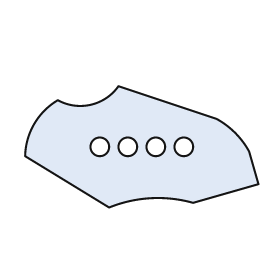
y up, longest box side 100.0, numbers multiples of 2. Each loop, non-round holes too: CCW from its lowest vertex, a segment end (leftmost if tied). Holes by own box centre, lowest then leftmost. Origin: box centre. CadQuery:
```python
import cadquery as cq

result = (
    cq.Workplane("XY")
    .moveTo(-14.0, -26.0)
    .threePointArc((4.0, -22.0), (22.0, -24.0))
    .lineTo(50.0, -16.0)
    .lineTo(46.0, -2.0)
    .threePointArc((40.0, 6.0), (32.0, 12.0))
    .lineTo(-10.0, 26.0)
    .threePointArc((-22.0, 18.0), (-36.0, 20.0))
    .threePointArc((-46.0, 10.0), (-50.0, -4.0))
    .close()
    .moveTo(-18.0, 0.0)
    .circle(4.0)
    .moveTo(-6.0, 0.0)
    .circle(4.0)
    .moveTo(6.0, 0.0)
    .circle(4.0)
    .moveTo(18.0, 0.0)
    .circle(4.0)
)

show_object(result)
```